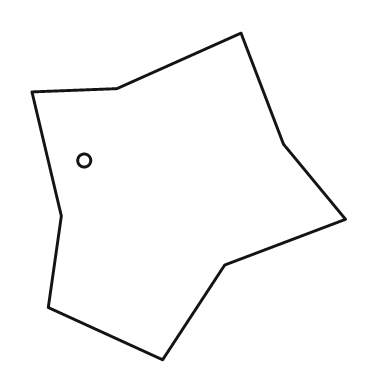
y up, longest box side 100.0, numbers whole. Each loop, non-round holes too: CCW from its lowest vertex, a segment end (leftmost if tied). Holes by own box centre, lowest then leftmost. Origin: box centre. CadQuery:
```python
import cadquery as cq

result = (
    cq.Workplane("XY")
    .moveTo(-8.0, -50.0)
    .lineTo(11.0, -21.0)
    .lineTo(48.0, -7.0)
    .lineTo(29.0, 16.0)
    .lineTo(16.0, 50.0)
    .lineTo(-22.0, 33.0)
    .lineTo(-48.0, 32.0)
    .lineTo(-39.0, -6.0)
    .lineTo(-43.0, -34.0)
    .close()
    .moveTo(-32.0, 11.0)
    .circle(2.0)
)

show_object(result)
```